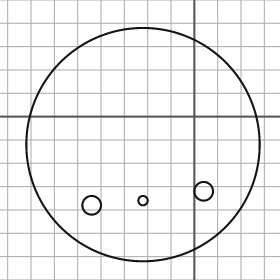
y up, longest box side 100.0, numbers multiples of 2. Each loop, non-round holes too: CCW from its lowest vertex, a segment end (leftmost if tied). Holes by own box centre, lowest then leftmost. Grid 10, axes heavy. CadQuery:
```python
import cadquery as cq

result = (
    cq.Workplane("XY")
    .moveTo(-22.0, -12.0)
    .circle(50.0)
    .moveTo(-44.0, -38.0)
    .circle(4.0)
    .moveTo(-22.0, -36.0)
    .circle(2.0)
    .moveTo(4.0, -32.0)
    .circle(4.0)
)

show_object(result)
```